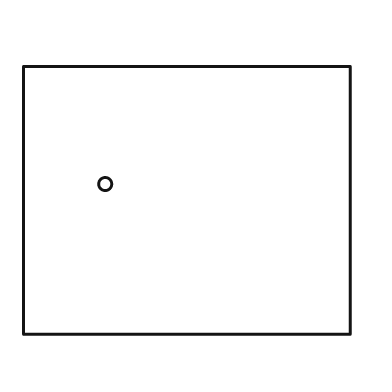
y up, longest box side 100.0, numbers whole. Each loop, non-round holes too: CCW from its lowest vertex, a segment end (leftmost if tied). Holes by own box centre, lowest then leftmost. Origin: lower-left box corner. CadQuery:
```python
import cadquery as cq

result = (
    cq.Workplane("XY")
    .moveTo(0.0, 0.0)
    .lineTo(100.0, 0.0)
    .lineTo(100.0, 82.0)
    .lineTo(0.0, 82.0)
    .close()
    .moveTo(25.0, 46.0)
    .circle(2.0)
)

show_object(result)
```